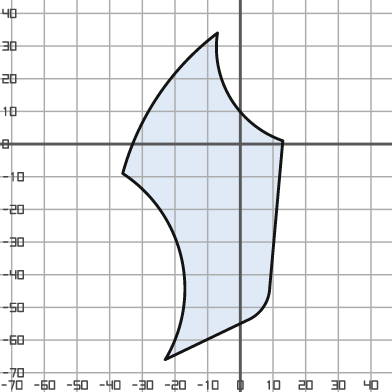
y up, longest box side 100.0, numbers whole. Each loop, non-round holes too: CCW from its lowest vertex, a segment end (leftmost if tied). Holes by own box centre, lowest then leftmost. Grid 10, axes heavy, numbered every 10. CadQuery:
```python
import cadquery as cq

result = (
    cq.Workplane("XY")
    .moveTo(-23.0, -66.0)
    .lineTo(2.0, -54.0)
    .threePointArc((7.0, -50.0), (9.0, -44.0))
    .lineTo(13.0, 1.0)
    .threePointArc((-3.0, 14.0), (-7.0, 34.0))
    .threePointArc((-25.0, 15.0), (-36.0, -9.0))
    .threePointArc((-18.0, -35.0), (-23.0, -66.0))
    .close()
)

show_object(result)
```